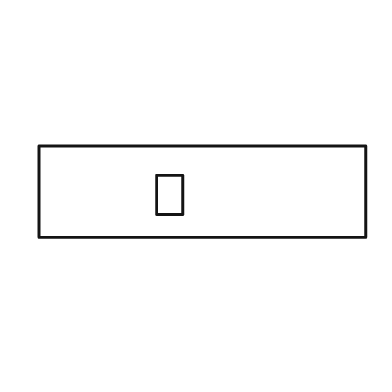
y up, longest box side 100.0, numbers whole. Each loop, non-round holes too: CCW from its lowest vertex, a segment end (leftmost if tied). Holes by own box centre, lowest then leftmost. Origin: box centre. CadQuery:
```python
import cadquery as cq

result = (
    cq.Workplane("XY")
    .moveTo(-50.0, -14.0)
    .lineTo(50.0, -14.0)
    .lineTo(50.0, 14.0)
    .lineTo(-50.0, 14.0)
    .close()
    .moveTo(-14.0, -7.0)
    .lineTo(-6.0, -7.0)
    .lineTo(-6.0, 5.0)
    .lineTo(-14.0, 5.0)
    .close()
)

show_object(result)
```